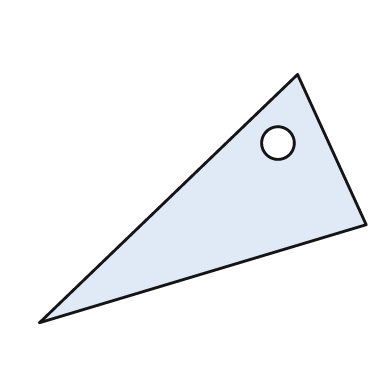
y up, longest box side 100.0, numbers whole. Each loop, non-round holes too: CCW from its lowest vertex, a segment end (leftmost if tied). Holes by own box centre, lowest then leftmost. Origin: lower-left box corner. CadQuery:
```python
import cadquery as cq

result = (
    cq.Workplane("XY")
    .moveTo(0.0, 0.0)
    .lineTo(100.0, 30.0)
    .lineTo(79.0, 76.0)
    .close()
    .moveTo(73.0, 55.0)
    .circle(5.0)
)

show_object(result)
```